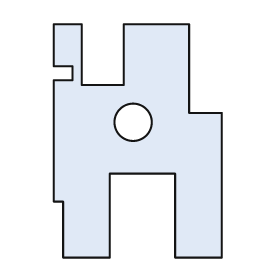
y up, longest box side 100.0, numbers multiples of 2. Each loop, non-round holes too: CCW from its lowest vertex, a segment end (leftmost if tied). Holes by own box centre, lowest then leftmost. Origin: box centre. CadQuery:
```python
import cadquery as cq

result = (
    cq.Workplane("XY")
    .moveTo(-32.0, -50.0)
    .lineTo(-12.0, -50.0)
    .lineTo(-12.0, -14.0)
    .lineTo(16.0, -14.0)
    .lineTo(16.0, -50.0)
    .lineTo(36.0, -50.0)
    .lineTo(36.0, 12.0)
    .lineTo(22.0, 12.0)
    .lineTo(22.0, 50.0)
    .lineTo(-6.0, 50.0)
    .lineTo(-6.0, 24.0)
    .lineTo(-24.0, 24.0)
    .lineTo(-24.0, 50.0)
    .lineTo(-36.0, 50.0)
    .lineTo(-36.0, 32.0)
    .lineTo(-28.0, 32.0)
    .lineTo(-28.0, 26.0)
    .lineTo(-36.0, 26.0)
    .lineTo(-36.0, -26.0)
    .lineTo(-32.0, -26.0)
    .close()
    .moveTo(-2.0, 8.0)
    .circle(8.0)
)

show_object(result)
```